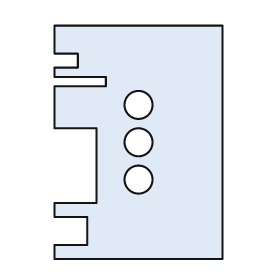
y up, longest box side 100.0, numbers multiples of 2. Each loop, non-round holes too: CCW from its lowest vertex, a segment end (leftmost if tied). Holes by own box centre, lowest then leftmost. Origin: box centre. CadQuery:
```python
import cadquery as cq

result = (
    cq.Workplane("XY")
    .moveTo(-36.0, -50.0)
    .lineTo(36.0, -50.0)
    .lineTo(36.0, 50.0)
    .lineTo(-36.0, 50.0)
    .lineTo(-36.0, 38.0)
    .lineTo(-26.0, 38.0)
    .lineTo(-26.0, 32.0)
    .lineTo(-36.0, 32.0)
    .lineTo(-36.0, 28.0)
    .lineTo(-14.0, 28.0)
    .lineTo(-14.0, 24.0)
    .lineTo(-36.0, 24.0)
    .lineTo(-36.0, 6.0)
    .lineTo(-18.0, 6.0)
    .lineTo(-18.0, -26.0)
    .lineTo(-36.0, -26.0)
    .lineTo(-36.0, -32.0)
    .lineTo(-22.0, -32.0)
    .lineTo(-22.0, -44.0)
    .lineTo(-36.0, -44.0)
    .close()
    .moveTo(0.0, -16.0)
    .circle(6.0)
    .moveTo(0.0, 0.0)
    .circle(6.0)
    .moveTo(0.0, 16.0)
    .circle(6.0)
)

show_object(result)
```